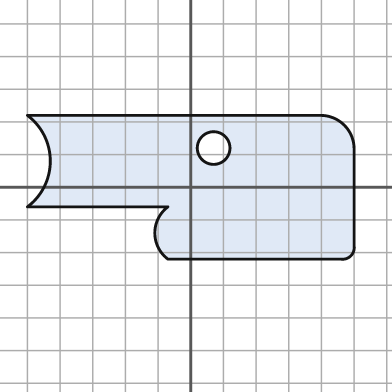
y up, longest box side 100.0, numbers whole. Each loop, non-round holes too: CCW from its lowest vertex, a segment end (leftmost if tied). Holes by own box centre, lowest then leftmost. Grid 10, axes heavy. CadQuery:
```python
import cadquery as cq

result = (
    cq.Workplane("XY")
    .moveTo(-7.0, -22.0)
    .lineTo(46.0, -22.0)
    .threePointArc((49.0, -21.0), (50.0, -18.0))
    .lineTo(50.0, 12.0)
    .threePointArc((47.0, 19.0), (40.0, 22.0))
    .lineTo(-50.0, 22.0)
    .threePointArc((-43.0, 8.0), (-50.0, -6.0))
    .lineTo(-7.0, -6.0)
    .threePointArc((-11.0, -14.0), (-7.0, -22.0))
    .close()
    .moveTo(7.0, 12.0)
    .circle(5.0)
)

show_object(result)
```